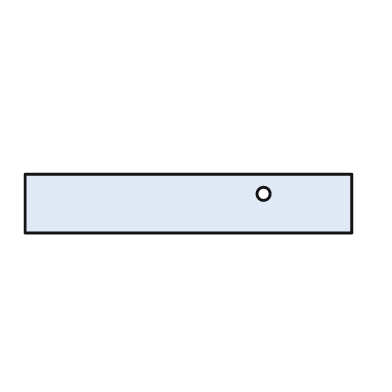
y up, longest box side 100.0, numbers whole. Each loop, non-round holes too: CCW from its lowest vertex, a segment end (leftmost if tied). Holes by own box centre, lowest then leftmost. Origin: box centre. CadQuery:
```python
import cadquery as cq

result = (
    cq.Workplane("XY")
    .moveTo(-50.0, -9.0)
    .lineTo(50.0, -9.0)
    .lineTo(50.0, 9.0)
    .lineTo(-50.0, 9.0)
    .close()
    .moveTo(23.0, 3.0)
    .circle(2.0)
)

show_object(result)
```